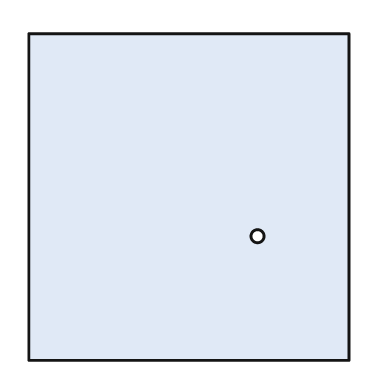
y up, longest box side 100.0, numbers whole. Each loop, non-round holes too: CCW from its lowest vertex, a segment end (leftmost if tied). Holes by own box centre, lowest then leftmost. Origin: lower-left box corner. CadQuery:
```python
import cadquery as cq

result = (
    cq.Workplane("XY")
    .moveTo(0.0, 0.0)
    .lineTo(98.0, 0.0)
    .lineTo(98.0, 100.0)
    .lineTo(0.0, 100.0)
    .close()
    .moveTo(70.0, 38.0)
    .circle(2.0)
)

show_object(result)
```